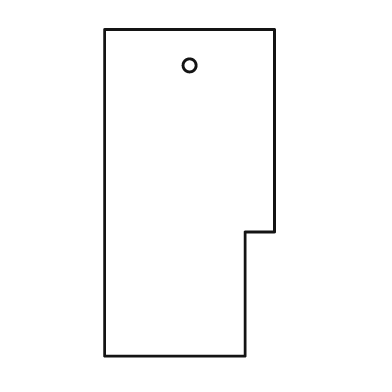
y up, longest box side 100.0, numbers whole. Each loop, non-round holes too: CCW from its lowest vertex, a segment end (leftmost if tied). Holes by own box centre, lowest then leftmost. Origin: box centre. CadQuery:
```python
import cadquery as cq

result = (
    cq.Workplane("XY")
    .moveTo(-26.0, -50.0)
    .lineTo(17.0, -50.0)
    .lineTo(17.0, -12.0)
    .lineTo(26.0, -12.0)
    .lineTo(26.0, 50.0)
    .lineTo(-26.0, 50.0)
    .close()
    .moveTo(0.0, 39.0)
    .circle(2.0)
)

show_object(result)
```